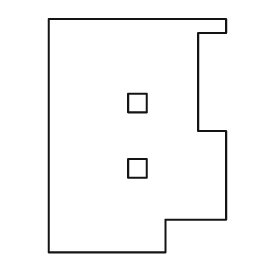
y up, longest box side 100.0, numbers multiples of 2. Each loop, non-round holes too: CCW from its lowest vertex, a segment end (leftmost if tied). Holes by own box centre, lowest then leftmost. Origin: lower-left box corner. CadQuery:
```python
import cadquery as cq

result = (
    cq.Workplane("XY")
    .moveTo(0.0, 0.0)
    .lineTo(50.0, 0.0)
    .lineTo(50.0, 14.0)
    .lineTo(76.0, 14.0)
    .lineTo(76.0, 52.0)
    .lineTo(64.0, 52.0)
    .lineTo(64.0, 94.0)
    .lineTo(76.0, 94.0)
    .lineTo(76.0, 100.0)
    .lineTo(0.0, 100.0)
    .close()
    .moveTo(34.0, 32.0)
    .lineTo(42.0, 32.0)
    .lineTo(42.0, 40.0)
    .lineTo(34.0, 40.0)
    .close()
    .moveTo(34.0, 60.0)
    .lineTo(42.0, 60.0)
    .lineTo(42.0, 68.0)
    .lineTo(34.0, 68.0)
    .close()
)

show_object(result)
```